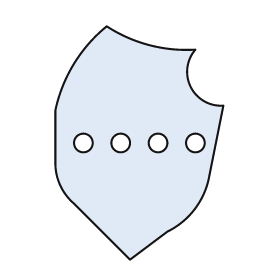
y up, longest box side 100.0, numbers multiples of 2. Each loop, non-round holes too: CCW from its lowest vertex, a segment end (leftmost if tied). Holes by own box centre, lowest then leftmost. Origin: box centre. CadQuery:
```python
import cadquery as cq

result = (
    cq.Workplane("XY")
    .moveTo(-4.0, -50.0)
    .lineTo(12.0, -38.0)
    .threePointArc((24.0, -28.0), (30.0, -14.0))
    .lineTo(36.0, 16.0)
    .threePointArc((22.0, 24.0), (24.0, 40.0))
    .threePointArc((4.0, 42.0), (-14.0, 50.0))
    .threePointArc((-28.0, 34.0), (-36.0, 14.0))
    .lineTo(-36.0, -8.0)
    .threePointArc((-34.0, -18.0), (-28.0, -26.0))
    .close()
    .moveTo(-24.0, 0.0)
    .circle(4.0)
    .moveTo(-8.0, 0.0)
    .circle(4.0)
    .moveTo(8.0, 0.0)
    .circle(4.0)
    .moveTo(24.0, 0.0)
    .circle(4.0)
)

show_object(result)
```